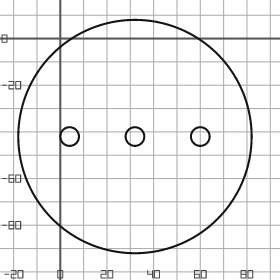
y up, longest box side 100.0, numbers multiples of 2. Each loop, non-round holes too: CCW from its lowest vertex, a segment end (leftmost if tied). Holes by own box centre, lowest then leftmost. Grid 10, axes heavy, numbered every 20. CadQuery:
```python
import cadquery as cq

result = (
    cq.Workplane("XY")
    .moveTo(32.0, -42.0)
    .circle(50.0)
    .moveTo(4.0, -42.0)
    .circle(4.0)
    .moveTo(32.0, -42.0)
    .circle(4.0)
    .moveTo(60.0, -42.0)
    .circle(4.0)
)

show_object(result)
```